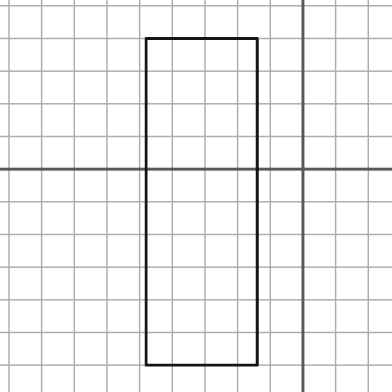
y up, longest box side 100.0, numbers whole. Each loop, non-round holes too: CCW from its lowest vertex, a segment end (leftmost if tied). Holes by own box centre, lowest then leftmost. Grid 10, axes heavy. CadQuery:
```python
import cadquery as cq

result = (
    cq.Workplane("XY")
    .moveTo(-48.0, -60.0)
    .lineTo(-14.0, -60.0)
    .lineTo(-14.0, 40.0)
    .lineTo(-48.0, 40.0)
    .close()
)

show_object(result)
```